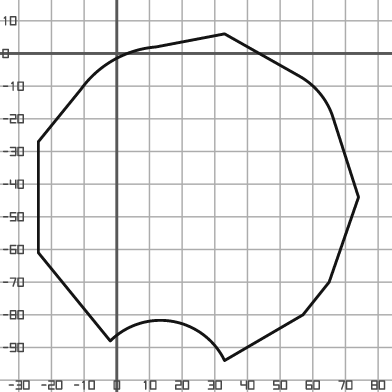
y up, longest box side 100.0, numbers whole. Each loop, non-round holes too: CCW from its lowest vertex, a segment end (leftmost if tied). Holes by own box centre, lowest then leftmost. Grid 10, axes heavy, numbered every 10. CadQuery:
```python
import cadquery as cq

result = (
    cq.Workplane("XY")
    .moveTo(33.0, -94.0)
    .lineTo(57.0, -80.0)
    .lineTo(65.0, -70.0)
    .lineTo(74.0, -44.0)
    .lineTo(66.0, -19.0)
    .threePointArc((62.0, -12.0), (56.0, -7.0))
    .lineTo(33.0, 6.0)
    .lineTo(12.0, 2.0)
    .threePointArc((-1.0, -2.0), (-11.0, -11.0))
    .lineTo(-24.0, -27.0)
    .lineTo(-24.0, -61.0)
    .lineTo(-2.0, -88.0)
    .threePointArc((17.0, -82.0), (33.0, -94.0))
    .close()
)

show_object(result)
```